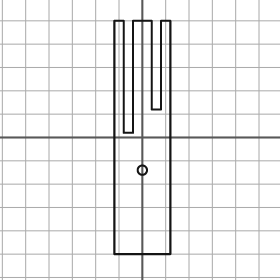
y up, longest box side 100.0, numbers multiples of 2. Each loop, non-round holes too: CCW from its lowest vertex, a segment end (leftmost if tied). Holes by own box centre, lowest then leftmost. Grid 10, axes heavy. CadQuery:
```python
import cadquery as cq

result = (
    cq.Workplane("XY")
    .moveTo(-12.0, -50.0)
    .lineTo(12.0, -50.0)
    .lineTo(12.0, 50.0)
    .lineTo(8.0, 50.0)
    .lineTo(8.0, 12.0)
    .lineTo(4.0, 12.0)
    .lineTo(4.0, 50.0)
    .lineTo(-4.0, 50.0)
    .lineTo(-4.0, 2.0)
    .lineTo(-8.0, 2.0)
    .lineTo(-8.0, 50.0)
    .lineTo(-12.0, 50.0)
    .close()
    .moveTo(0.0, -14.0)
    .circle(2.0)
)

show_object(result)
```